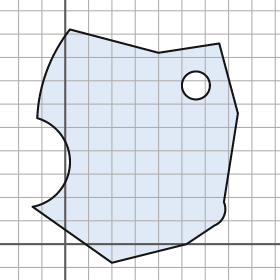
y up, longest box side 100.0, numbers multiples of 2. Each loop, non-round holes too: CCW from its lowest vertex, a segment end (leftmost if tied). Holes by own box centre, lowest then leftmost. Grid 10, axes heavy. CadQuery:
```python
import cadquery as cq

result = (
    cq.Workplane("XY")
    .moveTo(20.0, -8.0)
    .lineTo(52.0, 0.0)
    .lineTo(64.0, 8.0)
    .threePointArc((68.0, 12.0), (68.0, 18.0))
    .lineTo(74.0, 56.0)
    .lineTo(66.0, 86.0)
    .lineTo(40.0, 82.0)
    .lineTo(2.0, 92.0)
    .threePointArc((-8.0, 74.0), (-12.0, 54.0))
    .threePointArc((2.0, 34.0), (-14.0, 16.0))
    .close()
    .moveTo(56.0, 68.0)
    .circle(6.0)
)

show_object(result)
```